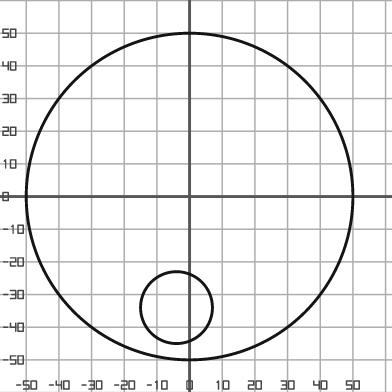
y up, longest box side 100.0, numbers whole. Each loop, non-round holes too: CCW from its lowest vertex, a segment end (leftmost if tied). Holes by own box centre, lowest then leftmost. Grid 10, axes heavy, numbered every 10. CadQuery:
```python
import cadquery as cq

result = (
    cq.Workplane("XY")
    .moveTo(0.0, 0.0)
    .circle(50.0)
    .moveTo(-4.0, -34.0)
    .circle(11.0)
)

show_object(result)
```